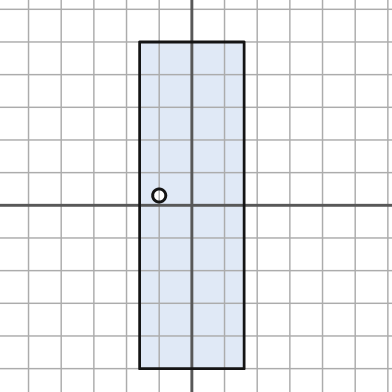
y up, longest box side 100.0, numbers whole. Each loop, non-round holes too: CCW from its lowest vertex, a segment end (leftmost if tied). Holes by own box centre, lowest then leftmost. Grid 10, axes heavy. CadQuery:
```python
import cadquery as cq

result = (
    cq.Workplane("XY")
    .moveTo(-16.0, -50.0)
    .lineTo(16.0, -50.0)
    .lineTo(16.0, 50.0)
    .lineTo(-16.0, 50.0)
    .close()
    .moveTo(-10.0, 3.0)
    .circle(2.0)
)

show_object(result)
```